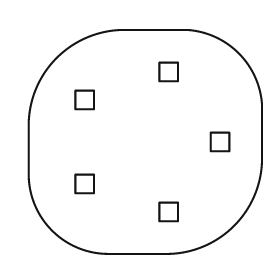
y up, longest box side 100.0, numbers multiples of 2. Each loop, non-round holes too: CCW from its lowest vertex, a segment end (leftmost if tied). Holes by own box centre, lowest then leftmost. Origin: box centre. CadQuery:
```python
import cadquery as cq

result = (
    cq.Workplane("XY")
    .moveTo(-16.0, -48.0)
    .lineTo(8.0, -48.0)
    .threePointArc((38.0, -36.0), (50.0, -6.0))
    .lineTo(50.0, 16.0)
    .threePointArc((40.0, 38.0), (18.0, 48.0))
    .lineTo(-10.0, 48.0)
    .threePointArc((-38.0, 36.0), (-50.0, 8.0))
    .lineTo(-50.0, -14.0)
    .threePointArc((-40.0, -38.0), (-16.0, -48.0))
    .close()
    .moveTo(6.0, -34.0)
    .lineTo(14.0, -34.0)
    .lineTo(14.0, -26.0)
    .lineTo(6.0, -26.0)
    .close()
    .moveTo(-30.0, -22.0)
    .lineTo(-22.0, -22.0)
    .lineTo(-22.0, -14.0)
    .lineTo(-30.0, -14.0)
    .close()
    .moveTo(28.0, -4.0)
    .lineTo(36.0, -4.0)
    .lineTo(36.0, 4.0)
    .lineTo(28.0, 4.0)
    .close()
    .moveTo(-30.0, 14.0)
    .lineTo(-22.0, 14.0)
    .lineTo(-22.0, 22.0)
    .lineTo(-30.0, 22.0)
    .close()
    .moveTo(6.0, 26.0)
    .lineTo(14.0, 26.0)
    .lineTo(14.0, 34.0)
    .lineTo(6.0, 34.0)
    .close()
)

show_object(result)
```